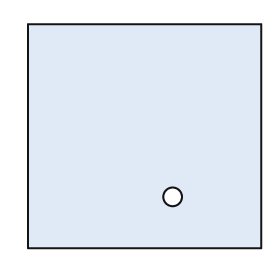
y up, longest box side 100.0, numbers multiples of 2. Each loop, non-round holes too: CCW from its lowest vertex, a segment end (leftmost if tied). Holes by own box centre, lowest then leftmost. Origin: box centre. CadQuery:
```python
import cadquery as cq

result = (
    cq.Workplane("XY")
    .moveTo(-50.0, -48.0)
    .lineTo(50.0, -48.0)
    .lineTo(50.0, 48.0)
    .lineTo(-50.0, 48.0)
    .close()
    .moveTo(12.0, -26.0)
    .circle(4.0)
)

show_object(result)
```